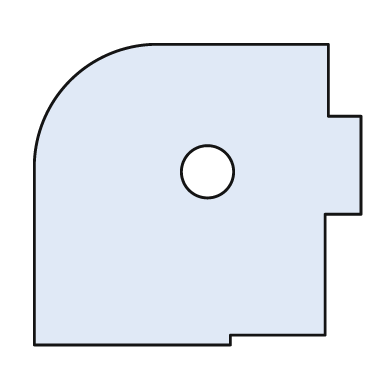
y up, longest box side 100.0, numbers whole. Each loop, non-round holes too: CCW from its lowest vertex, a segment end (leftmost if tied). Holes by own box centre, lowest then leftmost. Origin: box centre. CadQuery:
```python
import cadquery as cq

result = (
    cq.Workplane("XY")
    .moveTo(-50.0, -46.0)
    .lineTo(10.0, -46.0)
    .lineTo(10.0, -43.0)
    .lineTo(39.0, -43.0)
    .lineTo(39.0, -6.0)
    .lineTo(50.0, -6.0)
    .lineTo(50.0, 24.0)
    .lineTo(40.0, 24.0)
    .lineTo(40.0, 46.0)
    .lineTo(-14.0, 46.0)
    .threePointArc((-39.0, 35.0), (-50.0, 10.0))
    .close()
    .moveTo(3.0, 7.0)
    .circle(8.0)
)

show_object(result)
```